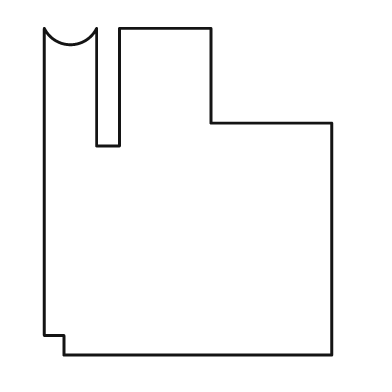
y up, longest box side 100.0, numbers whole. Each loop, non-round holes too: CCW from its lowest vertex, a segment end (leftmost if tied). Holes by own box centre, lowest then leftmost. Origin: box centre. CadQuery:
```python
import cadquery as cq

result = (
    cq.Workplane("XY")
    .moveTo(-38.0, -50.0)
    .lineTo(44.0, -50.0)
    .lineTo(44.0, 21.0)
    .lineTo(7.0, 21.0)
    .lineTo(7.0, 50.0)
    .lineTo(-21.0, 50.0)
    .lineTo(-21.0, 14.0)
    .lineTo(-28.0, 14.0)
    .lineTo(-28.0, 50.0)
    .threePointArc((-36.0, 45.0), (-44.0, 50.0))
    .lineTo(-44.0, -44.0)
    .lineTo(-38.0, -44.0)
    .close()
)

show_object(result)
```